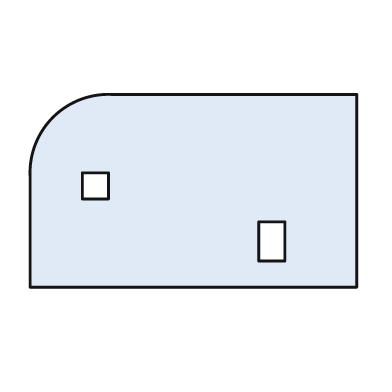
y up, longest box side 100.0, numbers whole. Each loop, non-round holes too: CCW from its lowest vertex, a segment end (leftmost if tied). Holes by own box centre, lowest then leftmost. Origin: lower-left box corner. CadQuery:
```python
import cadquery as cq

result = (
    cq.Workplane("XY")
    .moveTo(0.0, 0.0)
    .lineTo(100.0, 0.0)
    .lineTo(100.0, 59.0)
    .lineTo(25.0, 59.0)
    .threePointArc((7.0, 52.0), (0.0, 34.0))
    .close()
    .moveTo(70.0, 8.0)
    .lineTo(78.0, 8.0)
    .lineTo(78.0, 20.0)
    .lineTo(70.0, 20.0)
    .close()
    .moveTo(16.0, 27.0)
    .lineTo(24.0, 27.0)
    .lineTo(24.0, 35.0)
    .lineTo(16.0, 35.0)
    .close()
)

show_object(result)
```